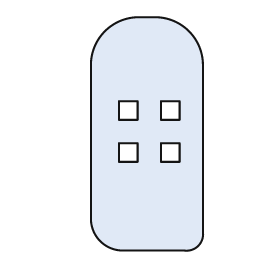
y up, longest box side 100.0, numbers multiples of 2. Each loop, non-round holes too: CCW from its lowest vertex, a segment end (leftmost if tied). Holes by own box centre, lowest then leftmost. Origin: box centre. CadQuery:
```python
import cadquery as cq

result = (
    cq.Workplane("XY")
    .moveTo(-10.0, -50.0)
    .lineTo(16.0, -50.0)
    .threePointArc((22.0, -48.0), (24.0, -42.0))
    .lineTo(24.0, 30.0)
    .threePointArc((18.0, 44.0), (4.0, 50.0))
    .lineTo(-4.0, 50.0)
    .threePointArc((-18.0, 44.0), (-24.0, 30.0))
    .lineTo(-24.0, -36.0)
    .threePointArc((-20.0, -46.0), (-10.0, -50.0))
    .close()
    .moveTo(-12.0, -12.0)
    .lineTo(-4.0, -12.0)
    .lineTo(-4.0, -4.0)
    .lineTo(-12.0, -4.0)
    .close()
    .moveTo(6.0, -12.0)
    .lineTo(14.0, -12.0)
    .lineTo(14.0, -4.0)
    .lineTo(6.0, -4.0)
    .close()
    .moveTo(-12.0, 6.0)
    .lineTo(-4.0, 6.0)
    .lineTo(-4.0, 14.0)
    .lineTo(-12.0, 14.0)
    .close()
    .moveTo(6.0, 6.0)
    .lineTo(14.0, 6.0)
    .lineTo(14.0, 14.0)
    .lineTo(6.0, 14.0)
    .close()
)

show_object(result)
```